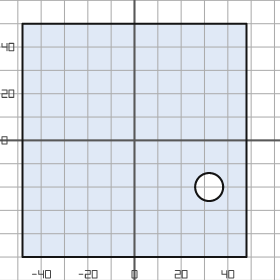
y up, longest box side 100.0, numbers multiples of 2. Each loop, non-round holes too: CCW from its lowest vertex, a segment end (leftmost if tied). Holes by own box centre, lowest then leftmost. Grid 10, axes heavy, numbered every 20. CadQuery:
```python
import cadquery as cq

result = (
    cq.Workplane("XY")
    .moveTo(-48.0, -50.0)
    .lineTo(48.0, -50.0)
    .lineTo(48.0, 50.0)
    .lineTo(-48.0, 50.0)
    .close()
    .moveTo(32.0, -20.0)
    .circle(6.0)
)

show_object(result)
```